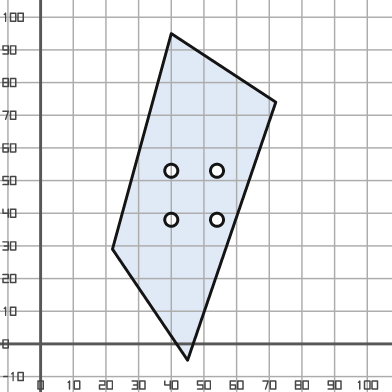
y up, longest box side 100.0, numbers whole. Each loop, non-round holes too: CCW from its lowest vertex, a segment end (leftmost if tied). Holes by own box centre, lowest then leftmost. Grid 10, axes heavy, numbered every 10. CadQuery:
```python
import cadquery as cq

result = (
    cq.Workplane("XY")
    .moveTo(45.0, -5.0)
    .lineTo(72.0, 74.0)
    .lineTo(40.0, 95.0)
    .lineTo(22.0, 29.0)
    .close()
    .moveTo(40.0, 38.0)
    .circle(2.0)
    .moveTo(54.0, 38.0)
    .circle(2.0)
    .moveTo(40.0, 53.0)
    .circle(2.0)
    .moveTo(54.0, 53.0)
    .circle(2.0)
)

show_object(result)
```